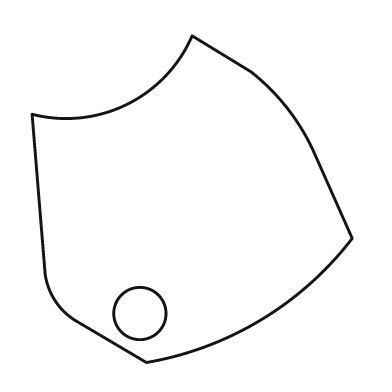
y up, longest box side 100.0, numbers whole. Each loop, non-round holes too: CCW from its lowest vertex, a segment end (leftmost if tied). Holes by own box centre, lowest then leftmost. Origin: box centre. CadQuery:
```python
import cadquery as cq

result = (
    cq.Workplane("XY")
    .moveTo(-14.0, -50.0)
    .threePointArc((21.0, -37.0), (49.0, -12.0))
    .lineTo(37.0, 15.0)
    .threePointArc((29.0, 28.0), (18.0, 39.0))
    .lineTo(0.0, 50.0)
    .threePointArc((-20.0, 29.0), (-49.0, 26.0))
    .lineTo(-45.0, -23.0)
    .threePointArc((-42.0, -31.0), (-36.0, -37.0))
    .close()
    .moveTo(-16.0, -35.0)
    .circle(8.0)
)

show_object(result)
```